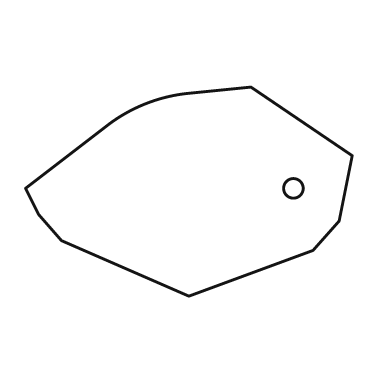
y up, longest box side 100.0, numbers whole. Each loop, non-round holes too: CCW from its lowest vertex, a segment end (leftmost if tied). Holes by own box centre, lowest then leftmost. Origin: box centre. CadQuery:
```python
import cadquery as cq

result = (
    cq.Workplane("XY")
    .moveTo(0.0, -32.0)
    .lineTo(38.0, -18.0)
    .lineTo(46.0, -9.0)
    .lineTo(50.0, 11.0)
    .lineTo(19.0, 32.0)
    .lineTo(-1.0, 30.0)
    .threePointArc((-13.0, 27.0), (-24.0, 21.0))
    .lineTo(-50.0, 1.0)
    .lineTo(-46.0, -7.0)
    .lineTo(-39.0, -15.0)
    .close()
    .moveTo(32.0, 1.0)
    .circle(3.0)
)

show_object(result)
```